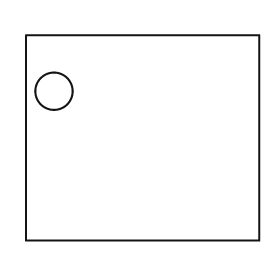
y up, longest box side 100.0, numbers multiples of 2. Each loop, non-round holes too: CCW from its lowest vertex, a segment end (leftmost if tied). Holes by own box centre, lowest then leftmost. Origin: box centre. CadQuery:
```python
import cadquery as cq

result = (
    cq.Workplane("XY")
    .moveTo(-50.0, -44.0)
    .lineTo(50.0, -44.0)
    .lineTo(50.0, 44.0)
    .lineTo(-50.0, 44.0)
    .close()
    .moveTo(-38.0, 20.0)
    .circle(8.0)
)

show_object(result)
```